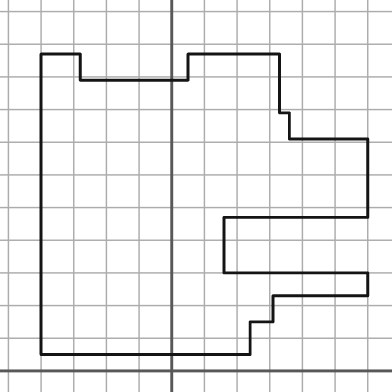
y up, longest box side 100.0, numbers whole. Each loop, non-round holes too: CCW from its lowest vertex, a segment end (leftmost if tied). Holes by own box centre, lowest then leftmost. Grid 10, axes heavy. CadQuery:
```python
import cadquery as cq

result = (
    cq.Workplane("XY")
    .moveTo(-40.0, 5.0)
    .lineTo(24.0, 5.0)
    .lineTo(24.0, 15.0)
    .lineTo(31.0, 15.0)
    .lineTo(31.0, 23.0)
    .lineTo(60.0, 23.0)
    .lineTo(60.0, 30.0)
    .lineTo(16.0, 30.0)
    .lineTo(16.0, 47.0)
    .lineTo(60.0, 47.0)
    .lineTo(60.0, 71.0)
    .lineTo(36.0, 71.0)
    .lineTo(36.0, 79.0)
    .lineTo(33.0, 79.0)
    .lineTo(33.0, 97.0)
    .lineTo(5.0, 97.0)
    .lineTo(5.0, 89.0)
    .lineTo(-28.0, 89.0)
    .lineTo(-28.0, 97.0)
    .lineTo(-40.0, 97.0)
    .close()
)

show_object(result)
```